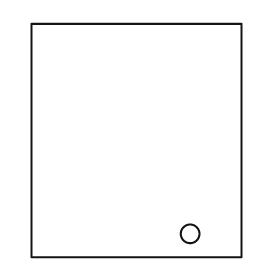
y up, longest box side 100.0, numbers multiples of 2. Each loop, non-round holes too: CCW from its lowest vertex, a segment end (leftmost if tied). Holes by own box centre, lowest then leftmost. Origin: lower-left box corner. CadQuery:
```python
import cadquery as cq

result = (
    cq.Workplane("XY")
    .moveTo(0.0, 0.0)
    .lineTo(90.0, 0.0)
    .lineTo(90.0, 100.0)
    .lineTo(0.0, 100.0)
    .close()
    .moveTo(68.0, 10.0)
    .circle(4.0)
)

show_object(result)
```